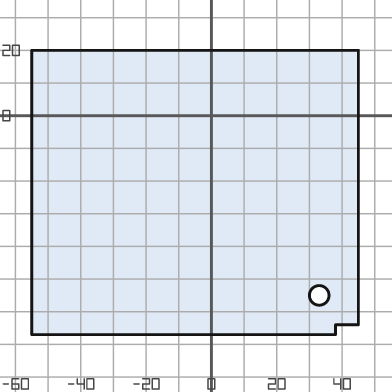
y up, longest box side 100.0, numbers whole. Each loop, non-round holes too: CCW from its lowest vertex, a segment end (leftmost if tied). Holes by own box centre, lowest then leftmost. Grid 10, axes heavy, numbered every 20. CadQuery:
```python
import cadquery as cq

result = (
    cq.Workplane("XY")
    .moveTo(-55.0, -67.0)
    .lineTo(38.0, -67.0)
    .lineTo(38.0, -64.0)
    .lineTo(45.0, -64.0)
    .lineTo(45.0, 20.0)
    .lineTo(-55.0, 20.0)
    .close()
    .moveTo(33.0, -55.0)
    .circle(3.0)
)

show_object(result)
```